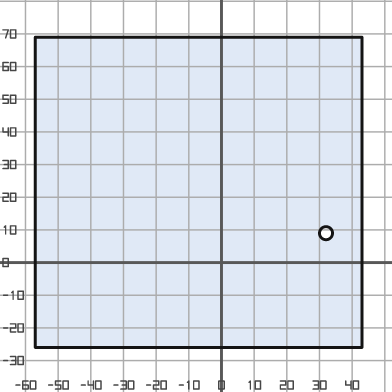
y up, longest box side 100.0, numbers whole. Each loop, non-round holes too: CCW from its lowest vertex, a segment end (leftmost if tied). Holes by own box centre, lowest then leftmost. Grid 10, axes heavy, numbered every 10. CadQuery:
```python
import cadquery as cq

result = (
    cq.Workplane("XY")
    .moveTo(-57.0, -26.0)
    .lineTo(43.0, -26.0)
    .lineTo(43.0, 69.0)
    .lineTo(-57.0, 69.0)
    .close()
    .moveTo(32.0, 9.0)
    .circle(2.0)
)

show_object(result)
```